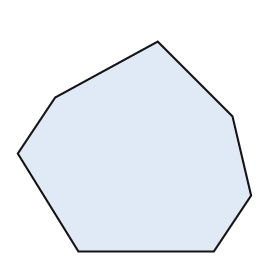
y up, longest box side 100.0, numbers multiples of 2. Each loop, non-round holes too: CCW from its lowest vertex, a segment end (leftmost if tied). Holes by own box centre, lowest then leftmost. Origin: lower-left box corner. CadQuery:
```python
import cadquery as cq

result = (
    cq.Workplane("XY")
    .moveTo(26.0, 0.0)
    .lineTo(84.0, 0.0)
    .lineTo(100.0, 24.0)
    .lineTo(92.0, 58.0)
    .lineTo(60.0, 90.0)
    .lineTo(16.0, 66.0)
    .lineTo(0.0, 42.0)
    .close()
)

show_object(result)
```